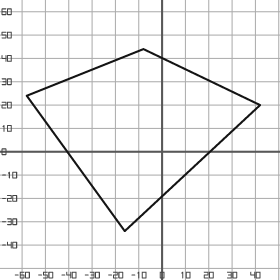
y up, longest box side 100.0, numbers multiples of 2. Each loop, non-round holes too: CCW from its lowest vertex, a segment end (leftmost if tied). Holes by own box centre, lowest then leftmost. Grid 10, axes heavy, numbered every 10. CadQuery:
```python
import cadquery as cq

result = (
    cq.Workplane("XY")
    .moveTo(-16.0, -34.0)
    .lineTo(42.0, 20.0)
    .lineTo(-8.0, 44.0)
    .lineTo(-58.0, 24.0)
    .close()
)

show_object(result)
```